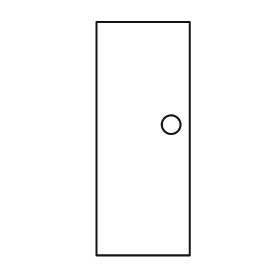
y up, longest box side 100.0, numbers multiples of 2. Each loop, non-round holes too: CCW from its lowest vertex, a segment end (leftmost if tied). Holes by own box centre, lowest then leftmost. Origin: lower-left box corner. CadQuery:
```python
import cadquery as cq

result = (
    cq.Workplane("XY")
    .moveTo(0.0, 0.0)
    .lineTo(40.0, 0.0)
    .lineTo(40.0, 100.0)
    .lineTo(0.0, 100.0)
    .close()
    .moveTo(32.0, 56.0)
    .circle(4.0)
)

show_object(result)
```